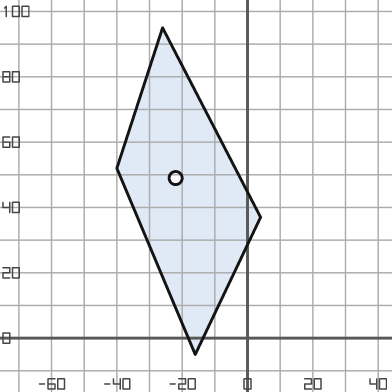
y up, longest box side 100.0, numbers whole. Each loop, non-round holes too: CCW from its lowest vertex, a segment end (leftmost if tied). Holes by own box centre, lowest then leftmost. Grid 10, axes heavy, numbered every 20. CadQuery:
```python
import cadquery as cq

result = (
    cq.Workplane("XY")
    .moveTo(-16.0, -5.0)
    .lineTo(4.0, 37.0)
    .lineTo(-26.0, 95.0)
    .lineTo(-40.0, 52.0)
    .close()
    .moveTo(-22.0, 49.0)
    .circle(2.0)
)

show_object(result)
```